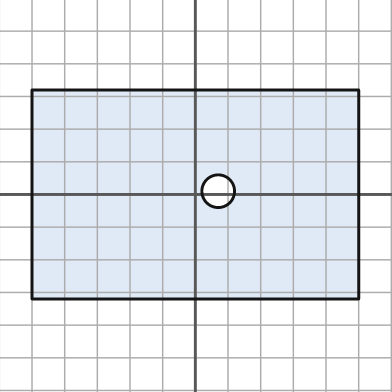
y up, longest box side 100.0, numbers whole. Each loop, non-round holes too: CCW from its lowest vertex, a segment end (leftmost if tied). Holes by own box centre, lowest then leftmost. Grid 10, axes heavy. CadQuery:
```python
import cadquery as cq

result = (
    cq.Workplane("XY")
    .moveTo(-50.0, -32.0)
    .lineTo(50.0, -32.0)
    .lineTo(50.0, 32.0)
    .lineTo(-50.0, 32.0)
    .close()
    .moveTo(7.0, 1.0)
    .circle(5.0)
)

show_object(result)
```